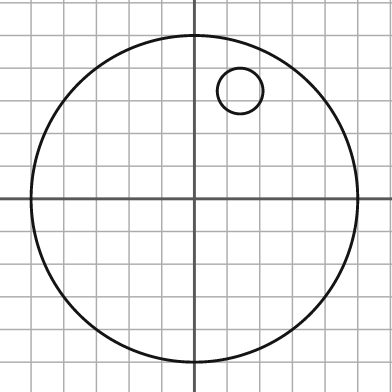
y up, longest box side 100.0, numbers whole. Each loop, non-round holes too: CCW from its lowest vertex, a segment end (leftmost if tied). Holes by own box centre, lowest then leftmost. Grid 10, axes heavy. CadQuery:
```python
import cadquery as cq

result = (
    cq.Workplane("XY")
    .moveTo(0.0, 0.0)
    .circle(50.0)
    .moveTo(14.0, 33.0)
    .circle(7.0)
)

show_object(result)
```